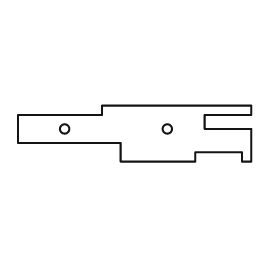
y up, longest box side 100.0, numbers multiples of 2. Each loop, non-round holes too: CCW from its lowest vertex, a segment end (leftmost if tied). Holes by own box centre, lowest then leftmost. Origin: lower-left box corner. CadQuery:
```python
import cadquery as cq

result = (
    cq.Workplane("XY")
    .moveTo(44.0, 0.0)
    .lineTo(76.0, 0.0)
    .lineTo(76.0, 4.0)
    .lineTo(96.0, 4.0)
    .lineTo(96.0, 0.0)
    .lineTo(100.0, 0.0)
    .lineTo(100.0, 14.0)
    .lineTo(80.0, 14.0)
    .lineTo(80.0, 20.0)
    .lineTo(100.0, 20.0)
    .lineTo(100.0, 24.0)
    .lineTo(36.0, 24.0)
    .lineTo(36.0, 20.0)
    .lineTo(0.0, 20.0)
    .lineTo(0.0, 8.0)
    .lineTo(44.0, 8.0)
    .close()
    .moveTo(20.0, 14.0)
    .circle(2.0)
    .moveTo(64.0, 14.0)
    .circle(2.0)
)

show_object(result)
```